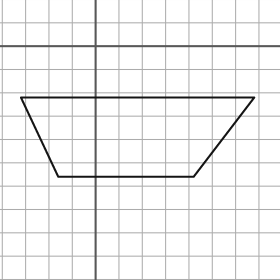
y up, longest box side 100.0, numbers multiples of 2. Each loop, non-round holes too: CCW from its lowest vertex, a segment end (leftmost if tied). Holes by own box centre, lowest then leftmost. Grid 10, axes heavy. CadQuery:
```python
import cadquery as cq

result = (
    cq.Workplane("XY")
    .moveTo(-16.0, -56.0)
    .lineTo(42.0, -56.0)
    .lineTo(68.0, -22.0)
    .lineTo(-32.0, -22.0)
    .close()
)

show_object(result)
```